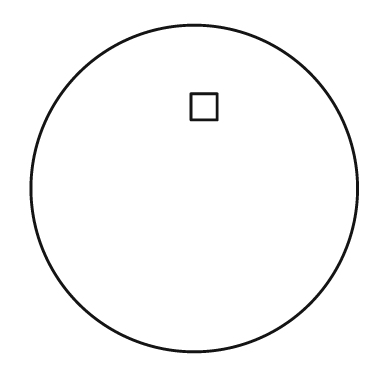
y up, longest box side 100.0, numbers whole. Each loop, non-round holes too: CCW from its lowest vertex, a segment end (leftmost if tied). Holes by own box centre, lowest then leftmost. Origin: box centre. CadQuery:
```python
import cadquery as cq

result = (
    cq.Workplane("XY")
    .moveTo(0.0, 0.0)
    .circle(50.0)
    .moveTo(-1.0, 21.0)
    .lineTo(7.0, 21.0)
    .lineTo(7.0, 29.0)
    .lineTo(-1.0, 29.0)
    .close()
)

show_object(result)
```